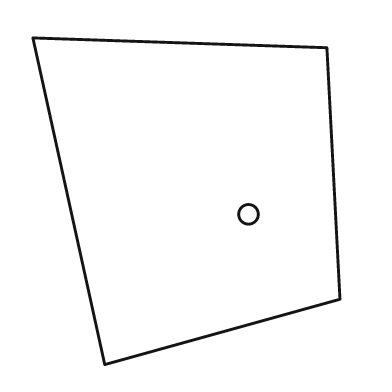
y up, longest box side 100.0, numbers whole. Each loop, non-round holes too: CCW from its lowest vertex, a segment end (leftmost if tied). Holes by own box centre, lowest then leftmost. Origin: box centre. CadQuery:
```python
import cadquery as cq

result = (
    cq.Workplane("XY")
    .moveTo(-25.0, -50.0)
    .lineTo(47.0, -30.0)
    .lineTo(43.0, 47.0)
    .lineTo(-47.0, 50.0)
    .close()
    .moveTo(19.0, -4.0)
    .circle(3.0)
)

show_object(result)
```